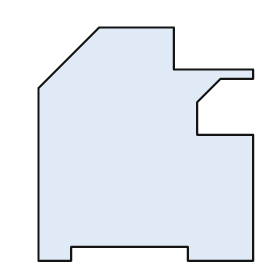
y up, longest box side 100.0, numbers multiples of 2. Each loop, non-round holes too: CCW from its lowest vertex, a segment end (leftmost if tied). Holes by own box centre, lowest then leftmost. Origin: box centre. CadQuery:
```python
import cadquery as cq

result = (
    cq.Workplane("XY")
    .moveTo(-46.0, -50.0)
    .lineTo(-32.0, -50.0)
    .lineTo(-32.0, -44.0)
    .lineTo(18.0, -44.0)
    .lineTo(18.0, -50.0)
    .lineTo(46.0, -50.0)
    .lineTo(46.0, 4.0)
    .lineTo(22.0, 4.0)
    .lineTo(22.0, 18.0)
    .lineTo(32.0, 28.0)
    .lineTo(46.0, 28.0)
    .lineTo(46.0, 32.0)
    .lineTo(12.0, 32.0)
    .lineTo(12.0, 50.0)
    .lineTo(-20.0, 50.0)
    .lineTo(-46.0, 24.0)
    .close()
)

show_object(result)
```